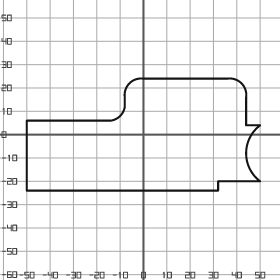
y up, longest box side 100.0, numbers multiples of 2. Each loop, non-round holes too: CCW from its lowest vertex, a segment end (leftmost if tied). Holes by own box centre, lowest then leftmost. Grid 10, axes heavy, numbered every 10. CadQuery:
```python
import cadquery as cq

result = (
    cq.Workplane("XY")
    .moveTo(-50.0, -24.0)
    .lineTo(32.0, -24.0)
    .lineTo(32.0, -20.0)
    .lineTo(50.0, -20.0)
    .threePointArc((44.0, -8.0), (50.0, 4.0))
    .lineTo(44.0, 4.0)
    .lineTo(44.0, 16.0)
    .threePointArc((42.0, 22.0), (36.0, 24.0))
    .lineTo(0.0, 24.0)
    .threePointArc((-6.0, 22.0), (-8.0, 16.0))
    .lineTo(-8.0, 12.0)
    .threePointArc((-10.0, 8.0), (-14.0, 6.0))
    .lineTo(-50.0, 6.0)
    .close()
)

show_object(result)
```